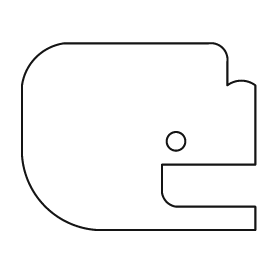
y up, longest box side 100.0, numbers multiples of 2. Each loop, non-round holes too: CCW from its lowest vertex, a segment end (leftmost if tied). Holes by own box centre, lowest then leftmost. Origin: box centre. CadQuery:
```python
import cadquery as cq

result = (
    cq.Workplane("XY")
    .moveTo(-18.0, -40.0)
    .lineTo(50.0, -40.0)
    .lineTo(50.0, -30.0)
    .lineTo(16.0, -30.0)
    .threePointArc((12.0, -28.0), (10.0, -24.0))
    .lineTo(10.0, -12.0)
    .lineTo(50.0, -12.0)
    .lineTo(50.0, 22.0)
    .threePointArc((44.0, 24.0), (38.0, 22.0))
    .lineTo(38.0, 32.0)
    .threePointArc((36.0, 38.0), (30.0, 40.0))
    .lineTo(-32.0, 40.0)
    .threePointArc((-44.0, 34.0), (-50.0, 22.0))
    .lineTo(-50.0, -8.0)
    .threePointArc((-40.0, -30.0), (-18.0, -40.0))
    .close()
    .moveTo(16.0, -2.0)
    .circle(4.0)
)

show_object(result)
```